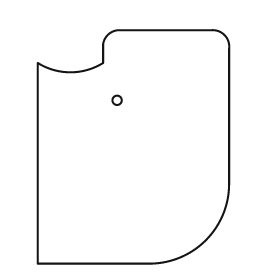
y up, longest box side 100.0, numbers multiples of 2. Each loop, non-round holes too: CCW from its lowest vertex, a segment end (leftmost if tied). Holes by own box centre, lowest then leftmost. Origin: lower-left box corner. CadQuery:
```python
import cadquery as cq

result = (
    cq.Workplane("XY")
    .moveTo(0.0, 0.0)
    .lineTo(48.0, 0.0)
    .threePointArc((72.0, 10.0), (82.0, 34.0))
    .lineTo(82.0, 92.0)
    .threePointArc((80.0, 98.0), (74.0, 100.0))
    .lineTo(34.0, 100.0)
    .threePointArc((30.0, 98.0), (28.0, 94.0))
    .lineTo(28.0, 86.0)
    .threePointArc((14.0, 82.0), (0.0, 86.0))
    .close()
    .moveTo(34.0, 70.0)
    .circle(2.0)
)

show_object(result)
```